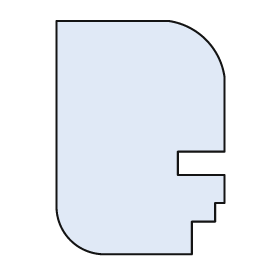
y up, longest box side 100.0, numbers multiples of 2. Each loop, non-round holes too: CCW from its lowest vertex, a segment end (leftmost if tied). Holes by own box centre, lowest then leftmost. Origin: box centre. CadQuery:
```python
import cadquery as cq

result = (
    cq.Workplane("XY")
    .moveTo(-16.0, -50.0)
    .lineTo(22.0, -50.0)
    .lineTo(22.0, -36.0)
    .lineTo(32.0, -36.0)
    .lineTo(32.0, -28.0)
    .lineTo(36.0, -28.0)
    .lineTo(36.0, -16.0)
    .lineTo(16.0, -16.0)
    .lineTo(16.0, -6.0)
    .lineTo(36.0, -6.0)
    .lineTo(36.0, 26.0)
    .threePointArc((28.0, 42.0), (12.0, 50.0))
    .lineTo(-36.0, 50.0)
    .lineTo(-36.0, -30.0)
    .threePointArc((-30.0, -44.0), (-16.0, -50.0))
    .close()
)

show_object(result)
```